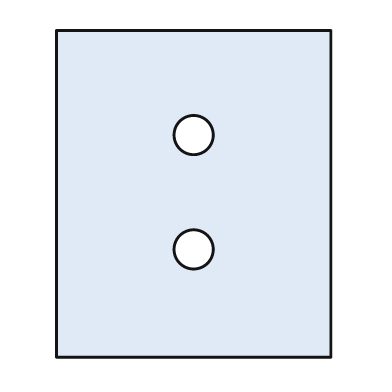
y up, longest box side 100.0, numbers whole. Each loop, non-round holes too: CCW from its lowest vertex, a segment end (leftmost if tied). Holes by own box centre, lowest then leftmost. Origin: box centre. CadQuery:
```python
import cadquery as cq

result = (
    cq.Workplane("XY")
    .moveTo(-42.0, -50.0)
    .lineTo(42.0, -50.0)
    .lineTo(42.0, 50.0)
    .lineTo(-42.0, 50.0)
    .close()
    .moveTo(0.0, -17.0)
    .circle(6.0)
    .moveTo(0.0, 18.0)
    .circle(6.0)
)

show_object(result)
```